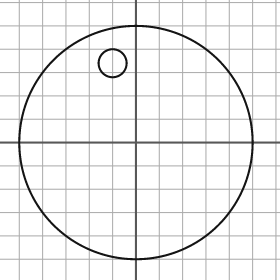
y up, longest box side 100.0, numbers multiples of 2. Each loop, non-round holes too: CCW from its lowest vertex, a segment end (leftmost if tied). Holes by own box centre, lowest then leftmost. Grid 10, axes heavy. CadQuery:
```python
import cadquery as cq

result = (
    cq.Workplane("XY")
    .moveTo(0.0, 0.0)
    .circle(50.0)
    .moveTo(-10.0, 34.0)
    .circle(6.0)
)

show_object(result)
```